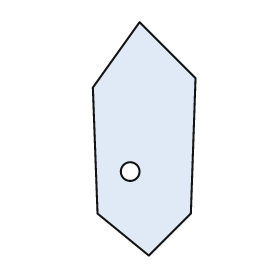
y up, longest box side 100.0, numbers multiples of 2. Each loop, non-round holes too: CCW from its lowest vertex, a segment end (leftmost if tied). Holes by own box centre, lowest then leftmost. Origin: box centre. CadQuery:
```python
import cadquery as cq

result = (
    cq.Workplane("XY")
    .moveTo(2.0, -50.0)
    .lineTo(20.0, -32.0)
    .lineTo(22.0, 26.0)
    .lineTo(-2.0, 50.0)
    .lineTo(-22.0, 22.0)
    .lineTo(-20.0, -32.0)
    .close()
    .moveTo(-6.0, -14.0)
    .circle(4.0)
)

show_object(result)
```